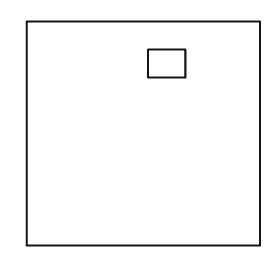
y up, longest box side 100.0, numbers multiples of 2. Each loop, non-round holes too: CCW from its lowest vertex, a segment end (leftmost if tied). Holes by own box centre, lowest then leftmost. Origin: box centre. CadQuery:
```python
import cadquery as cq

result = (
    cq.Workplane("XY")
    .moveTo(-50.0, -48.0)
    .lineTo(50.0, -48.0)
    .lineTo(50.0, 48.0)
    .lineTo(-50.0, 48.0)
    .close()
    .moveTo(2.0, 24.0)
    .lineTo(18.0, 24.0)
    .lineTo(18.0, 36.0)
    .lineTo(2.0, 36.0)
    .close()
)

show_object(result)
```